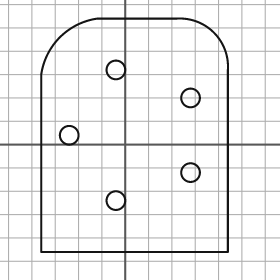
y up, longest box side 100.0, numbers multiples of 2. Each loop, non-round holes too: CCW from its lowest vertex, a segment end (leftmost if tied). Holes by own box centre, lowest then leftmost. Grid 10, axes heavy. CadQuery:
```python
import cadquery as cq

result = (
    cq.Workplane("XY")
    .moveTo(-36.0, -46.0)
    .lineTo(44.0, -46.0)
    .lineTo(44.0, 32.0)
    .threePointArc((38.0, 48.0), (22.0, 54.0))
    .lineTo(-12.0, 54.0)
    .threePointArc((-28.0, 46.0), (-36.0, 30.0))
    .close()
    .moveTo(-4.0, -24.0)
    .circle(4.0)
    .moveTo(28.0, -12.0)
    .circle(4.0)
    .moveTo(-24.0, 4.0)
    .circle(4.0)
    .moveTo(28.0, 20.0)
    .circle(4.0)
    .moveTo(-4.0, 32.0)
    .circle(4.0)
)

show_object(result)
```